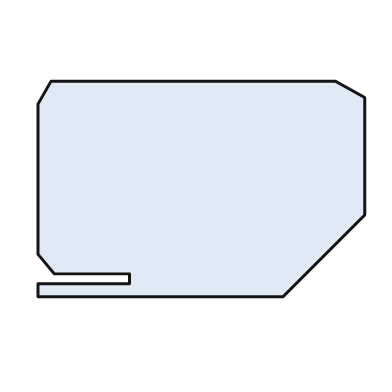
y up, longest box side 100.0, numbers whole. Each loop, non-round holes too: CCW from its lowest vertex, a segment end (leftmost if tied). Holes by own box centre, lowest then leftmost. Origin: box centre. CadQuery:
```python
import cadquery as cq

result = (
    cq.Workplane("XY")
    .moveTo(-50.0, -33.0)
    .lineTo(25.0, -33.0)
    .lineTo(50.0, -8.0)
    .lineTo(50.0, 28.0)
    .lineTo(41.0, 33.0)
    .lineTo(-46.0, 33.0)
    .lineTo(-50.0, 26.0)
    .lineTo(-50.0, -20.0)
    .lineTo(-45.0, -26.0)
    .lineTo(-22.0, -26.0)
    .lineTo(-22.0, -29.0)
    .lineTo(-50.0, -29.0)
    .close()
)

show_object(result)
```